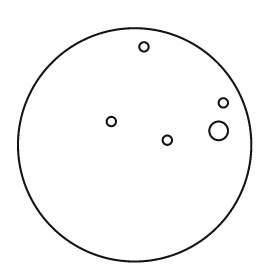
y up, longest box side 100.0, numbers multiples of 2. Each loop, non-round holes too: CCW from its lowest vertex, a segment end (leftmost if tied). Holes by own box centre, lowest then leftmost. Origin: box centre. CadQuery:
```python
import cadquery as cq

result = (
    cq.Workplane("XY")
    .moveTo(0.0, 0.0)
    .circle(50.0)
    .moveTo(14.0, 2.0)
    .circle(2.0)
    .moveTo(36.0, 6.0)
    .circle(4.0)
    .moveTo(-10.0, 10.0)
    .circle(2.0)
    .moveTo(38.0, 18.0)
    .circle(2.0)
    .moveTo(4.0, 42.0)
    .circle(2.0)
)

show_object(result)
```